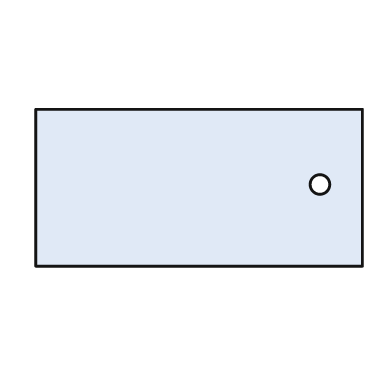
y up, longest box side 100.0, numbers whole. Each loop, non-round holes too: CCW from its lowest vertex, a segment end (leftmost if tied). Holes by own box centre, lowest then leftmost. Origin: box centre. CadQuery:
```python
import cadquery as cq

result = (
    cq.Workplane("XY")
    .moveTo(-50.0, -24.0)
    .lineTo(50.0, -24.0)
    .lineTo(50.0, 24.0)
    .lineTo(-50.0, 24.0)
    .close()
    .moveTo(37.0, 1.0)
    .circle(3.0)
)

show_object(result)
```